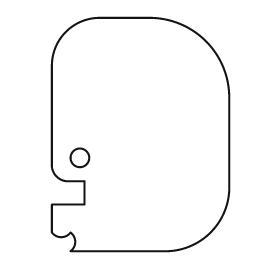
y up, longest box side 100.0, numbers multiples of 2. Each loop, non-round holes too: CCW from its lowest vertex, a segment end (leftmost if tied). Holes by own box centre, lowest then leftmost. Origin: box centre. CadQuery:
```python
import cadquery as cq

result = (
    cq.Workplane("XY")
    .moveTo(-30.0, -50.0)
    .lineTo(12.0, -50.0)
    .threePointArc((30.0, -42.0), (38.0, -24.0))
    .lineTo(38.0, 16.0)
    .threePointArc((28.0, 40.0), (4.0, 50.0))
    .lineTo(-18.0, 50.0)
    .threePointArc((-32.0, 44.0), (-38.0, 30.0))
    .lineTo(-38.0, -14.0)
    .threePointArc((-36.0, -18.0), (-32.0, -20.0))
    .lineTo(-24.0, -20.0)
    .lineTo(-24.0, -30.0)
    .lineTo(-38.0, -30.0)
    .lineTo(-38.0, -42.0)
    .threePointArc((-34.0, -44.0), (-30.0, -42.0))
    .threePointArc((-28.0, -46.0), (-30.0, -50.0))
    .close()
    .moveTo(-26.0, -10.0)
    .circle(4.0)
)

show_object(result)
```